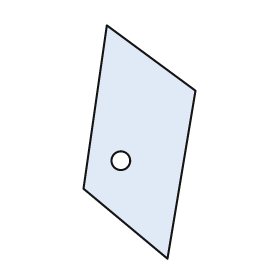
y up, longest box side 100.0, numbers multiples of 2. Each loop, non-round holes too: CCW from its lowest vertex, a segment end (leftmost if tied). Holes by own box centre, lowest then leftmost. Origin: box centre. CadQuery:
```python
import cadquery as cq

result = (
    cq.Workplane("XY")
    .moveTo(12.0, -50.0)
    .lineTo(24.0, 22.0)
    .lineTo(-14.0, 50.0)
    .lineTo(-24.0, -20.0)
    .close()
    .moveTo(-8.0, -8.0)
    .circle(4.0)
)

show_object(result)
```